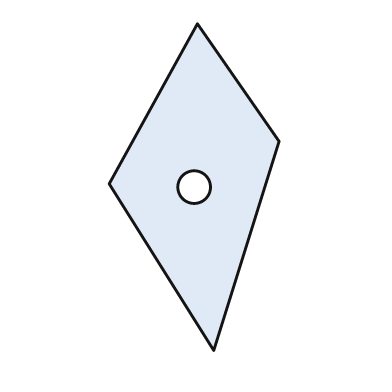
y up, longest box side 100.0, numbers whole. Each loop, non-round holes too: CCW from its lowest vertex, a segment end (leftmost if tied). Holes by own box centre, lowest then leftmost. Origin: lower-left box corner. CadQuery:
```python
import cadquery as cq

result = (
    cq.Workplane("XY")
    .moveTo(32.0, 0.0)
    .lineTo(52.0, 64.0)
    .lineTo(27.0, 100.0)
    .lineTo(0.0, 51.0)
    .close()
    .moveTo(26.0, 50.0)
    .circle(5.0)
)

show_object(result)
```